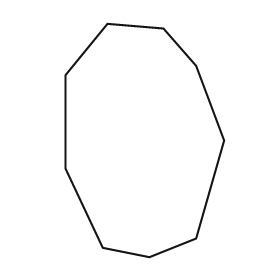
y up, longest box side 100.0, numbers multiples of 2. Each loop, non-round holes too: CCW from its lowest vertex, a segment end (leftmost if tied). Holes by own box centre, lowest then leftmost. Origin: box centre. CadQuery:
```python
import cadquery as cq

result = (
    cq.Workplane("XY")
    .moveTo(2.0, -50.0)
    .lineTo(22.0, -42.0)
    .lineTo(34.0, 0.0)
    .lineTo(22.0, 32.0)
    .lineTo(8.0, 48.0)
    .lineTo(-16.0, 50.0)
    .lineTo(-34.0, 28.0)
    .lineTo(-34.0, -12.0)
    .lineTo(-18.0, -46.0)
    .close()
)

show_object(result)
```